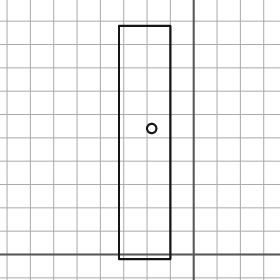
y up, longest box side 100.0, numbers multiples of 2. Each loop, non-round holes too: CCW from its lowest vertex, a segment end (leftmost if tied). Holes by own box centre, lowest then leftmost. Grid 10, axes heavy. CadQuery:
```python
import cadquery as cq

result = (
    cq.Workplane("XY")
    .moveTo(-32.0, -2.0)
    .lineTo(-10.0, -2.0)
    .lineTo(-10.0, 98.0)
    .lineTo(-32.0, 98.0)
    .close()
    .moveTo(-18.0, 54.0)
    .circle(2.0)
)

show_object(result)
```